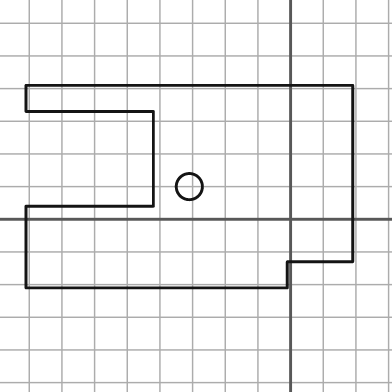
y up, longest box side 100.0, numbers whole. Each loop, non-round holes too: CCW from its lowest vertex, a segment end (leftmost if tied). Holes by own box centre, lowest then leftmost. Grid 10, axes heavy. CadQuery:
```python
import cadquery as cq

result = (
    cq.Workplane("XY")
    .moveTo(-81.0, -21.0)
    .lineTo(-1.0, -21.0)
    .lineTo(-1.0, -13.0)
    .lineTo(19.0, -13.0)
    .lineTo(19.0, 41.0)
    .lineTo(-81.0, 41.0)
    .lineTo(-81.0, 33.0)
    .lineTo(-42.0, 33.0)
    .lineTo(-42.0, 4.0)
    .lineTo(-81.0, 4.0)
    .close()
    .moveTo(-31.0, 10.0)
    .circle(4.0)
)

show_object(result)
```